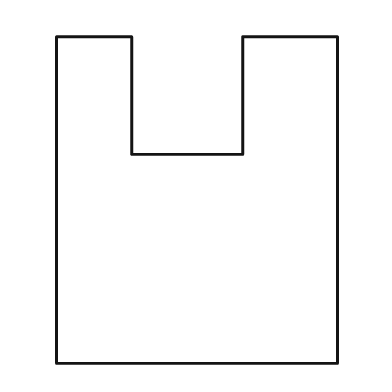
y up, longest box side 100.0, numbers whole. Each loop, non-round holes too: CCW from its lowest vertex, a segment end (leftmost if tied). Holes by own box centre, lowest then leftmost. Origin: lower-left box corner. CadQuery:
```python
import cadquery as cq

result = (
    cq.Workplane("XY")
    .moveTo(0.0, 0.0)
    .lineTo(86.0, 0.0)
    .lineTo(86.0, 100.0)
    .lineTo(57.0, 100.0)
    .lineTo(57.0, 64.0)
    .lineTo(23.0, 64.0)
    .lineTo(23.0, 100.0)
    .lineTo(0.0, 100.0)
    .close()
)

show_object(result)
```